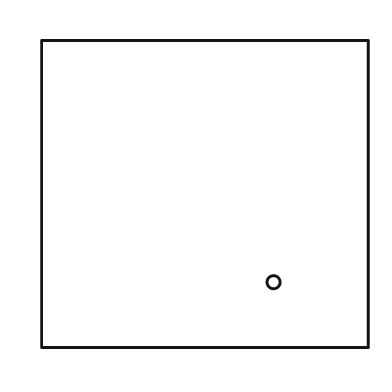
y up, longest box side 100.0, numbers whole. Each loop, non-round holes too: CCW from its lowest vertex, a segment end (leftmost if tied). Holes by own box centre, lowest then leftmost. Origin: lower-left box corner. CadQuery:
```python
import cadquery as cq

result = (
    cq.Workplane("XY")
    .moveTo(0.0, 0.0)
    .lineTo(100.0, 0.0)
    .lineTo(100.0, 94.0)
    .lineTo(0.0, 94.0)
    .close()
    .moveTo(71.0, 20.0)
    .circle(2.0)
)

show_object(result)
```